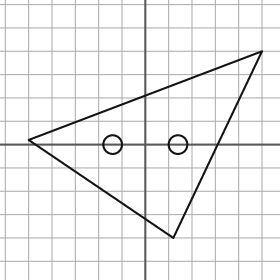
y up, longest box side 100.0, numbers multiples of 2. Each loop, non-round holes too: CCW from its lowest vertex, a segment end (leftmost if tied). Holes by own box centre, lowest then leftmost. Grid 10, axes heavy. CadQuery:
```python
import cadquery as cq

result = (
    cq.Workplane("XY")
    .moveTo(12.0, -40.0)
    .lineTo(50.0, 40.0)
    .lineTo(-50.0, 2.0)
    .close()
    .moveTo(-14.0, 0.0)
    .circle(4.0)
    .moveTo(14.0, 0.0)
    .circle(4.0)
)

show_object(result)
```